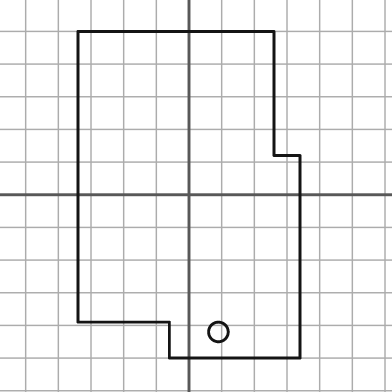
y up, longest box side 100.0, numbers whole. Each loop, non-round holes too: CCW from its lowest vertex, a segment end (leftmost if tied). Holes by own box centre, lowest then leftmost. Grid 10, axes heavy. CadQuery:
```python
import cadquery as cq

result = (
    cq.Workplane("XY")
    .moveTo(-6.0, -50.0)
    .lineTo(34.0, -50.0)
    .lineTo(34.0, 12.0)
    .lineTo(26.0, 12.0)
    .lineTo(26.0, 50.0)
    .lineTo(-34.0, 50.0)
    .lineTo(-34.0, -39.0)
    .lineTo(-6.0, -39.0)
    .close()
    .moveTo(9.0, -42.0)
    .circle(3.0)
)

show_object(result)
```